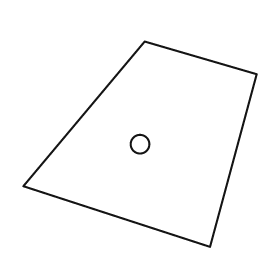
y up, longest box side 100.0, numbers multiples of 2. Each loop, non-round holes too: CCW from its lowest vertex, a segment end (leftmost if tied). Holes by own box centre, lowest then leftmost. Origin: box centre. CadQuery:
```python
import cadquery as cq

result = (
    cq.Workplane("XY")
    .moveTo(30.0, -44.0)
    .lineTo(50.0, 30.0)
    .lineTo(2.0, 44.0)
    .lineTo(-50.0, -18.0)
    .close()
    .moveTo(0.0, 0.0)
    .circle(4.0)
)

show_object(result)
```